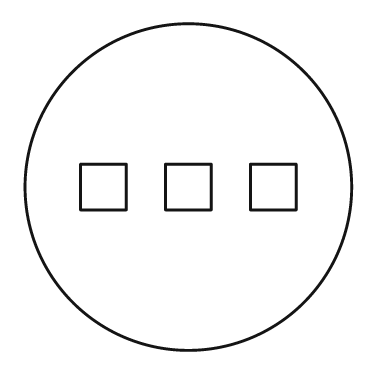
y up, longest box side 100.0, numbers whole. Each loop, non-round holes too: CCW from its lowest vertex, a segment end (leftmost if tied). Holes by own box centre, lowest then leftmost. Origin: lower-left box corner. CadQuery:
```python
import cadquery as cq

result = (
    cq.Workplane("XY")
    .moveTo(50.0, 50.0)
    .circle(50.0)
    .moveTo(17.0, 43.0)
    .lineTo(31.0, 43.0)
    .lineTo(31.0, 57.0)
    .lineTo(17.0, 57.0)
    .close()
    .moveTo(43.0, 43.0)
    .lineTo(57.0, 43.0)
    .lineTo(57.0, 57.0)
    .lineTo(43.0, 57.0)
    .close()
    .moveTo(69.0, 43.0)
    .lineTo(83.0, 43.0)
    .lineTo(83.0, 57.0)
    .lineTo(69.0, 57.0)
    .close()
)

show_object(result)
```